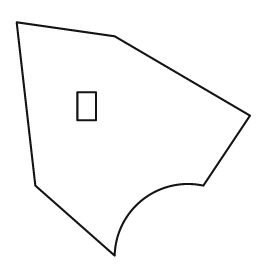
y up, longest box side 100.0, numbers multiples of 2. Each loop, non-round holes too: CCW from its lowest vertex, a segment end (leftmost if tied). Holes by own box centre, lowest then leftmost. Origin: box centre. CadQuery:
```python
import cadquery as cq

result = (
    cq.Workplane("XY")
    .moveTo(-8.0, -50.0)
    .threePointArc((4.0, -26.0), (30.0, -20.0))
    .lineTo(50.0, 10.0)
    .lineTo(-8.0, 44.0)
    .lineTo(-50.0, 50.0)
    .lineTo(-42.0, -20.0)
    .close()
    .moveTo(-24.0, 8.0)
    .lineTo(-16.0, 8.0)
    .lineTo(-16.0, 20.0)
    .lineTo(-24.0, 20.0)
    .close()
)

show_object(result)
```